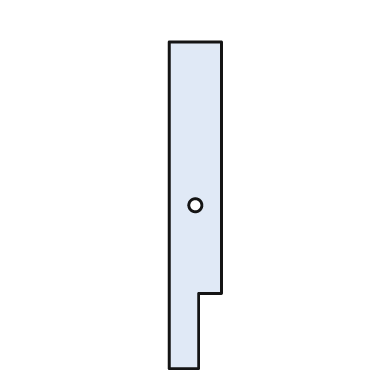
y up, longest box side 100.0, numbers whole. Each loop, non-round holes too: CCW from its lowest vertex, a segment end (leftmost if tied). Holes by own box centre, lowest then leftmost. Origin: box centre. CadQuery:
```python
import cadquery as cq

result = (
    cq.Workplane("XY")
    .moveTo(-8.0, -50.0)
    .lineTo(1.0, -50.0)
    .lineTo(1.0, -27.0)
    .lineTo(8.0, -27.0)
    .lineTo(8.0, 50.0)
    .lineTo(-8.0, 50.0)
    .close()
    .moveTo(0.0, 0.0)
    .circle(2.0)
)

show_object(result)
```